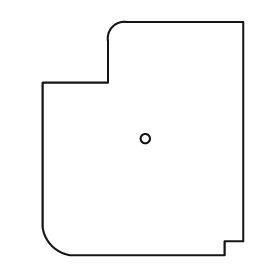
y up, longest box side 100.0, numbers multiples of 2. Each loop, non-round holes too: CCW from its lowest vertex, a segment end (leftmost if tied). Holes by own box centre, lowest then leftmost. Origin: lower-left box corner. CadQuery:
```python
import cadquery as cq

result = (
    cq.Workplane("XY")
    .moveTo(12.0, 0.0)
    .lineTo(78.0, 0.0)
    .lineTo(78.0, 6.0)
    .lineTo(86.0, 6.0)
    .lineTo(86.0, 100.0)
    .lineTo(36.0, 100.0)
    .threePointArc((30.0, 98.0), (28.0, 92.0))
    .lineTo(28.0, 74.0)
    .lineTo(0.0, 74.0)
    .lineTo(0.0, 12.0)
    .threePointArc((4.0, 4.0), (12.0, 0.0))
    .close()
    .moveTo(44.0, 50.0)
    .circle(2.0)
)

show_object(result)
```